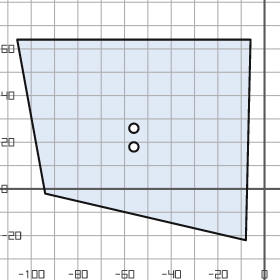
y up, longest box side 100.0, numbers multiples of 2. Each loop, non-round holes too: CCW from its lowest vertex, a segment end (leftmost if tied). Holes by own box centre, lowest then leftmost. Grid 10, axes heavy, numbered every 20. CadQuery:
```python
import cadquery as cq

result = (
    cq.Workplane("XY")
    .moveTo(-8.0, -22.0)
    .lineTo(-6.0, 64.0)
    .lineTo(-106.0, 64.0)
    .lineTo(-94.0, -2.0)
    .close()
    .moveTo(-56.0, 18.0)
    .circle(2.0)
    .moveTo(-56.0, 26.0)
    .circle(2.0)
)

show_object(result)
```